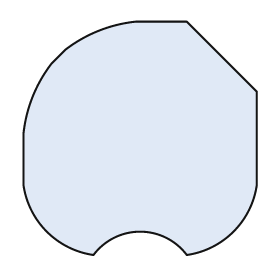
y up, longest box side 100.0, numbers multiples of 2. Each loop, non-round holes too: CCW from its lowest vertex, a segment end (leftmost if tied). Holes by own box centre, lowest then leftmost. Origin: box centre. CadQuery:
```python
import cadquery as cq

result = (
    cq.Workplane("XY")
    .moveTo(-20.0, -50.0)
    .threePointArc((0.0, -40.0), (20.0, -50.0))
    .threePointArc((40.0, -40.0), (50.0, -20.0))
    .lineTo(50.0, 20.0)
    .lineTo(20.0, 50.0)
    .lineTo(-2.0, 50.0)
    .threePointArc((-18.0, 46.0), (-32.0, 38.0))
    .lineTo(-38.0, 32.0)
    .threePointArc((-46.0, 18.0), (-50.0, 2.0))
    .lineTo(-50.0, -20.0)
    .threePointArc((-40.0, -40.0), (-20.0, -50.0))
    .close()
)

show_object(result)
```